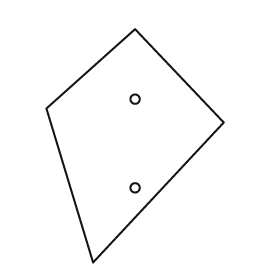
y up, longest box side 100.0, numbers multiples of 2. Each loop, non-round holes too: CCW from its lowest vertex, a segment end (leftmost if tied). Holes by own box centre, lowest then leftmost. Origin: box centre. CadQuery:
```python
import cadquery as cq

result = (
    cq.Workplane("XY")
    .moveTo(-18.0, -50.0)
    .lineTo(38.0, 10.0)
    .lineTo(0.0, 50.0)
    .lineTo(-38.0, 16.0)
    .close()
    .moveTo(0.0, -18.0)
    .circle(2.0)
    .moveTo(0.0, 20.0)
    .circle(2.0)
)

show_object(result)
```